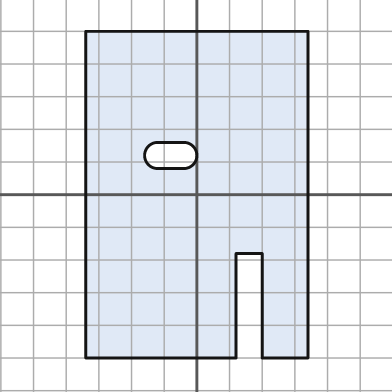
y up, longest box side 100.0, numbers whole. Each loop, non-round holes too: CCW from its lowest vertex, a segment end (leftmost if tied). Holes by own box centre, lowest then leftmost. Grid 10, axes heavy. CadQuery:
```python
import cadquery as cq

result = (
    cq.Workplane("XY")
    .moveTo(-34.0, -50.0)
    .lineTo(12.0, -50.0)
    .lineTo(12.0, -18.0)
    .lineTo(20.0, -18.0)
    .lineTo(20.0, -50.0)
    .lineTo(34.0, -50.0)
    .lineTo(34.0, 50.0)
    .lineTo(-34.0, 50.0)
    .close()
    .moveTo(-12.0, 8.0)
    .lineTo(-4.0, 8.0)
    .threePointArc((0.0, 12.0), (-4.0, 16.0))
    .lineTo(-12.0, 16.0)
    .threePointArc((-16.0, 12.0), (-12.0, 8.0))
    .close()
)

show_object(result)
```